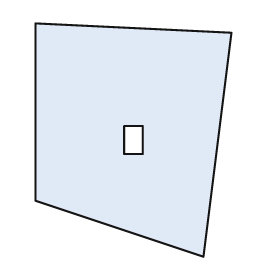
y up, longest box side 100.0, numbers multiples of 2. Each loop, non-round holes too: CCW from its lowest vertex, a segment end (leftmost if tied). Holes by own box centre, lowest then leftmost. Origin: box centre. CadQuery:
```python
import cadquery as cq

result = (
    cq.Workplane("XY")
    .moveTo(30.0, -50.0)
    .lineTo(42.0, 46.0)
    .lineTo(-42.0, 50.0)
    .lineTo(-42.0, -26.0)
    .close()
    .moveTo(-4.0, -6.0)
    .lineTo(4.0, -6.0)
    .lineTo(4.0, 6.0)
    .lineTo(-4.0, 6.0)
    .close()
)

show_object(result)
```